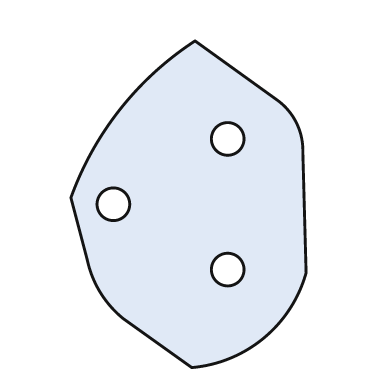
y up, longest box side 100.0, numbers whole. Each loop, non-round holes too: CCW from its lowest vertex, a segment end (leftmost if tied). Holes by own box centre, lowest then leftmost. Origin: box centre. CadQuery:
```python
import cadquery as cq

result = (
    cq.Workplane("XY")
    .moveTo(1.0, -50.0)
    .threePointArc((23.0, -41.0), (36.0, -21.0))
    .lineTo(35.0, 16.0)
    .threePointArc((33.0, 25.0), (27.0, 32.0))
    .lineTo(2.0, 50.0)
    .threePointArc((-21.0, 29.0), (-36.0, 2.0))
    .lineTo(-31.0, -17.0)
    .threePointArc((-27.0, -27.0), (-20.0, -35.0))
    .close()
    .moveTo(12.0, -20.0)
    .circle(5.0)
    .moveTo(-23.0, 0.0)
    .circle(5.0)
    .moveTo(12.0, 20.0)
    .circle(5.0)
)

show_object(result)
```